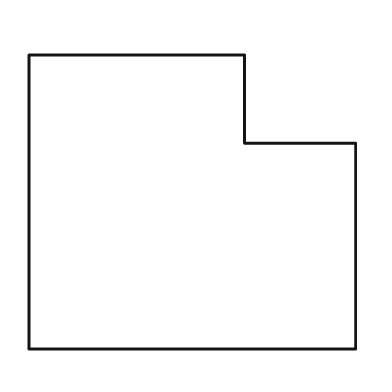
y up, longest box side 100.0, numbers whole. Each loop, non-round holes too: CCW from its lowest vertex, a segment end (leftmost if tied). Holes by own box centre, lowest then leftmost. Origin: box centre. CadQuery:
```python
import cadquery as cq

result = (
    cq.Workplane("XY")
    .moveTo(-50.0, -45.0)
    .lineTo(50.0, -45.0)
    .lineTo(50.0, 18.0)
    .lineTo(16.0, 18.0)
    .lineTo(16.0, 45.0)
    .lineTo(-50.0, 45.0)
    .close()
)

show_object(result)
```